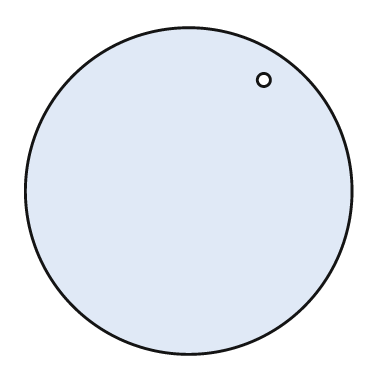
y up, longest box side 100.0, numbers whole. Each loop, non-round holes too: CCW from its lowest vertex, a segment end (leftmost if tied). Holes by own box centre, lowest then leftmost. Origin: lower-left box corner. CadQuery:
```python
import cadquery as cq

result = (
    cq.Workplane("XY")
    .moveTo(50.0, 50.0)
    .circle(50.0)
    .moveTo(73.0, 84.0)
    .circle(2.0)
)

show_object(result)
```